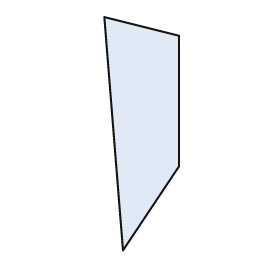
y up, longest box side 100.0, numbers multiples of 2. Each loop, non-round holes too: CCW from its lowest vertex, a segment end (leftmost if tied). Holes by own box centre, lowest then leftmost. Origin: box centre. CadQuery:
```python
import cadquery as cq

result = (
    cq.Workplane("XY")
    .moveTo(-8.0, -50.0)
    .lineTo(16.0, -14.0)
    .lineTo(16.0, 42.0)
    .lineTo(-16.0, 50.0)
    .close()
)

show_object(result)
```